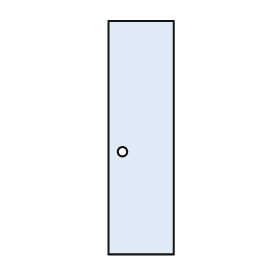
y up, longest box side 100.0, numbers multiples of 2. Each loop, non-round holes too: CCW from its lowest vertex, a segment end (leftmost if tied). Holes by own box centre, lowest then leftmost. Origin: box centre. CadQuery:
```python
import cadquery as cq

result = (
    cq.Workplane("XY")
    .moveTo(-14.0, -50.0)
    .lineTo(14.0, -50.0)
    .lineTo(14.0, 50.0)
    .lineTo(-14.0, 50.0)
    .close()
    .moveTo(-8.0, -6.0)
    .circle(2.0)
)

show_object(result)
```